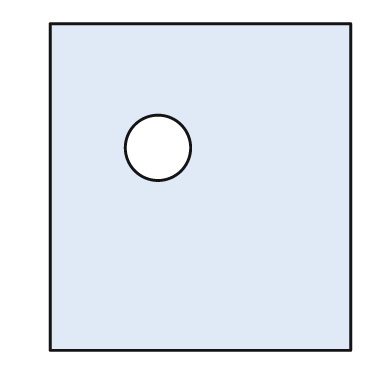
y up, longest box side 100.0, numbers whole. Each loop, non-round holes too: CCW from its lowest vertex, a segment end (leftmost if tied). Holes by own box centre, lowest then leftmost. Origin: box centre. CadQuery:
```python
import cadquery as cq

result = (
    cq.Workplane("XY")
    .moveTo(-46.0, -50.0)
    .lineTo(46.0, -50.0)
    .lineTo(46.0, 50.0)
    .lineTo(-46.0, 50.0)
    .close()
    .moveTo(-13.0, 12.0)
    .circle(10.0)
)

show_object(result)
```